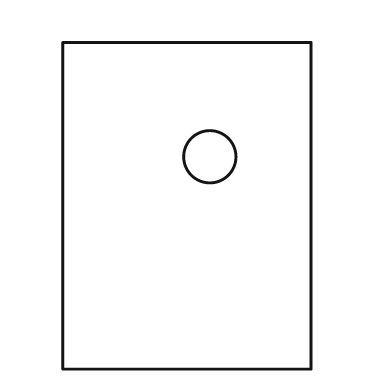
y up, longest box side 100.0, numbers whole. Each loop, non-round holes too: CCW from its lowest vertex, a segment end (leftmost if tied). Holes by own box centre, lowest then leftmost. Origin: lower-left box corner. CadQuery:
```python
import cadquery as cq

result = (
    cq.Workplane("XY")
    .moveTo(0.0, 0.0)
    .lineTo(76.0, 0.0)
    .lineTo(76.0, 100.0)
    .lineTo(0.0, 100.0)
    .close()
    .moveTo(45.0, 65.0)
    .circle(8.0)
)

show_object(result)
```